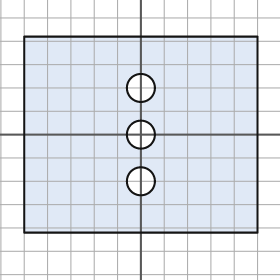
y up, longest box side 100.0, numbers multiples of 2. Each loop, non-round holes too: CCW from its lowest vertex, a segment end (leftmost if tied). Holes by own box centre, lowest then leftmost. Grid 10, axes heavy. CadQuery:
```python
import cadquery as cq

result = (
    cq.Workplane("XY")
    .moveTo(-50.0, -42.0)
    .lineTo(50.0, -42.0)
    .lineTo(50.0, 42.0)
    .lineTo(-50.0, 42.0)
    .close()
    .moveTo(0.0, -20.0)
    .circle(6.0)
    .moveTo(0.0, 0.0)
    .circle(6.0)
    .moveTo(0.0, 20.0)
    .circle(6.0)
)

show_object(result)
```